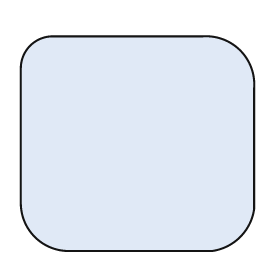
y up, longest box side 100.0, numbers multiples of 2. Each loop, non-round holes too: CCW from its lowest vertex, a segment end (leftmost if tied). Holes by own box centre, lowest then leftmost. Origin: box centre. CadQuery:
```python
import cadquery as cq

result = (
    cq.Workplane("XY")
    .moveTo(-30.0, -46.0)
    .lineTo(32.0, -46.0)
    .threePointArc((44.0, -40.0), (50.0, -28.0))
    .lineTo(50.0, 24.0)
    .threePointArc((44.0, 40.0), (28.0, 46.0))
    .lineTo(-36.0, 46.0)
    .threePointArc((-46.0, 42.0), (-50.0, 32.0))
    .lineTo(-50.0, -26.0)
    .threePointArc((-44.0, -40.0), (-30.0, -46.0))
    .close()
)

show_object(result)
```